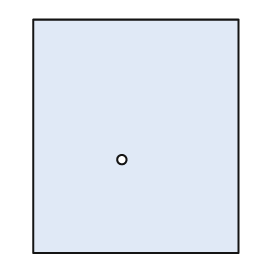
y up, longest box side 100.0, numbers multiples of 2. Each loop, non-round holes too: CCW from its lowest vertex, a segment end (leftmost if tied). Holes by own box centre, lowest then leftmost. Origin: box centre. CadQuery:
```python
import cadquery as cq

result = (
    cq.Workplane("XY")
    .moveTo(-44.0, -50.0)
    .lineTo(44.0, -50.0)
    .lineTo(44.0, 50.0)
    .lineTo(-44.0, 50.0)
    .close()
    .moveTo(-6.0, -10.0)
    .circle(2.0)
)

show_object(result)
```